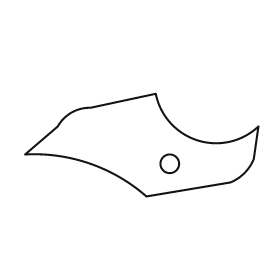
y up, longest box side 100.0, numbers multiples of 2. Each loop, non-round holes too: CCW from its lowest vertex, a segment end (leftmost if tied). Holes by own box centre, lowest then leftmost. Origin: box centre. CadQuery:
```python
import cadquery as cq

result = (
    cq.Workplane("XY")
    .moveTo(2.0, -22.0)
    .lineTo(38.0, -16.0)
    .threePointArc((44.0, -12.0), (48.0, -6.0))
    .lineTo(50.0, 8.0)
    .threePointArc((24.0, 2.0), (6.0, 22.0))
    .lineTo(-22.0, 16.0)
    .threePointArc((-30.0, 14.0), (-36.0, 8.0))
    .lineTo(-50.0, -4.0)
    .threePointArc((-22.0, -8.0), (2.0, -22.0))
    .close()
    .moveTo(12.0, -8.0)
    .circle(4.0)
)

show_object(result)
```